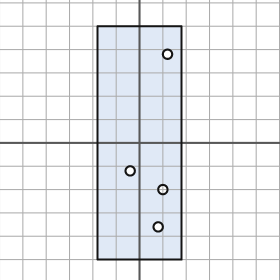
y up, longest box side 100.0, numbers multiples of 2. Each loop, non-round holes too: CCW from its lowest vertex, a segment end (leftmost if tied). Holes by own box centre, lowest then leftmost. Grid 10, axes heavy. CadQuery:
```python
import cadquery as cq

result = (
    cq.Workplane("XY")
    .moveTo(-18.0, -50.0)
    .lineTo(18.0, -50.0)
    .lineTo(18.0, 50.0)
    .lineTo(-18.0, 50.0)
    .close()
    .moveTo(8.0, -36.0)
    .circle(2.0)
    .moveTo(10.0, -20.0)
    .circle(2.0)
    .moveTo(-4.0, -12.0)
    .circle(2.0)
    .moveTo(12.0, 38.0)
    .circle(2.0)
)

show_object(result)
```